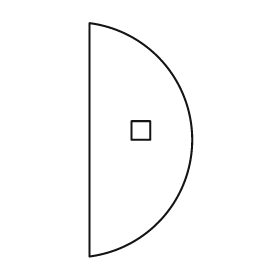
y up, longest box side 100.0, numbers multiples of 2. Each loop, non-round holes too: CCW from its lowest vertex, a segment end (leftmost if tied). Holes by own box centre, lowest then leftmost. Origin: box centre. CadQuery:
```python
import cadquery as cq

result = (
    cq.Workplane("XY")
    .moveTo(-22.0, -50.0)
    .threePointArc((22.0, 0.0), (-22.0, 50.0))
    .close()
    .moveTo(-4.0, 0.0)
    .lineTo(4.0, 0.0)
    .lineTo(4.0, 8.0)
    .lineTo(-4.0, 8.0)
    .close()
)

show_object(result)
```